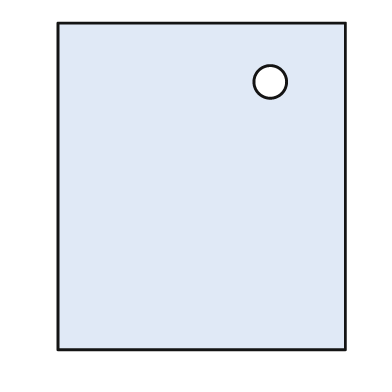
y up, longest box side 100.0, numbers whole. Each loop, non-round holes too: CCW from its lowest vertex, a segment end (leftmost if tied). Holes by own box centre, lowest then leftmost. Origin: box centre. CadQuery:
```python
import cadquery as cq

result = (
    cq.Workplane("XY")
    .moveTo(-44.0, -50.0)
    .lineTo(44.0, -50.0)
    .lineTo(44.0, 50.0)
    .lineTo(-44.0, 50.0)
    .close()
    .moveTo(21.0, 32.0)
    .circle(5.0)
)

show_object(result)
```